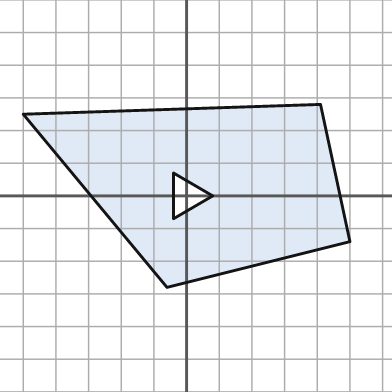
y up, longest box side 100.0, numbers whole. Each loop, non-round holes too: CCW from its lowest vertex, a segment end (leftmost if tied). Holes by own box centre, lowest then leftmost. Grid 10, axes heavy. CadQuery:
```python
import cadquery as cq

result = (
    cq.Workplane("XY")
    .moveTo(-6.0, -28.0)
    .lineTo(50.0, -14.0)
    .lineTo(41.0, 28.0)
    .lineTo(-50.0, 25.0)
    .close()
    .moveTo(-4.0, -7.0)
    .lineTo(8.0, 0.0)
    .lineTo(-4.0, 7.0)
    .close()
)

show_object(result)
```